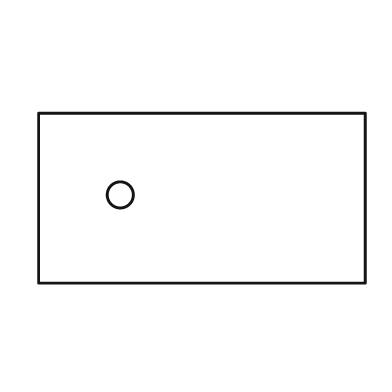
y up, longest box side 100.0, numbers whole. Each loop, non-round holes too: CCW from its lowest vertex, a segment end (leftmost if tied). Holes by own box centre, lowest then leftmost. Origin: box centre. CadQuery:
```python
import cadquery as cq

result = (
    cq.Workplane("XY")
    .moveTo(-50.0, -26.0)
    .lineTo(50.0, -26.0)
    .lineTo(50.0, 26.0)
    .lineTo(-50.0, 26.0)
    .close()
    .moveTo(-25.0, 1.0)
    .circle(4.0)
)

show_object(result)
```